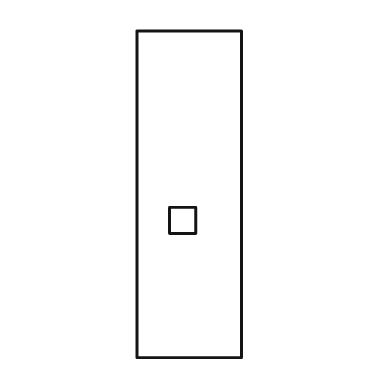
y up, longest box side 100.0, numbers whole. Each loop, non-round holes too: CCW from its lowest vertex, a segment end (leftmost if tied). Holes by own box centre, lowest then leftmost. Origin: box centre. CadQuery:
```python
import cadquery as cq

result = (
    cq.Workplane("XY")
    .moveTo(-16.0, -50.0)
    .lineTo(16.0, -50.0)
    .lineTo(16.0, 50.0)
    .lineTo(-16.0, 50.0)
    .close()
    .moveTo(-6.0, -12.0)
    .lineTo(2.0, -12.0)
    .lineTo(2.0, -4.0)
    .lineTo(-6.0, -4.0)
    .close()
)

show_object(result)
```